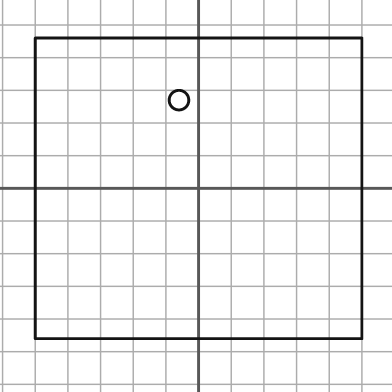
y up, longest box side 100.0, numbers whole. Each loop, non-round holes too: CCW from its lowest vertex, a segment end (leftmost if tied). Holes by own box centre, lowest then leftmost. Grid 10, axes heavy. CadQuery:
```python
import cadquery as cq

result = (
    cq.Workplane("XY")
    .moveTo(-50.0, -46.0)
    .lineTo(50.0, -46.0)
    .lineTo(50.0, 46.0)
    .lineTo(-50.0, 46.0)
    .close()
    .moveTo(-6.0, 27.0)
    .circle(3.0)
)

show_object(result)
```